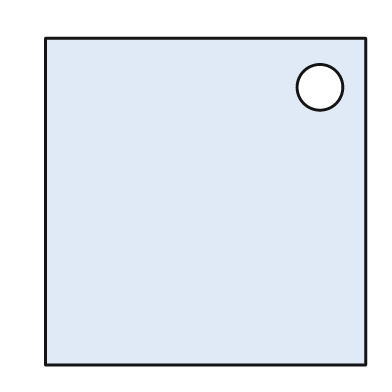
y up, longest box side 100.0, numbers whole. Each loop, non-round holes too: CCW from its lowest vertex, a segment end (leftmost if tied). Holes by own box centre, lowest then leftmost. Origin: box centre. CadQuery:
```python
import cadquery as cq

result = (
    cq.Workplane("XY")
    .moveTo(-49.0, -50.0)
    .lineTo(49.0, -50.0)
    .lineTo(49.0, 50.0)
    .lineTo(-49.0, 50.0)
    .close()
    .moveTo(35.0, 35.0)
    .circle(7.0)
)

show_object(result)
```